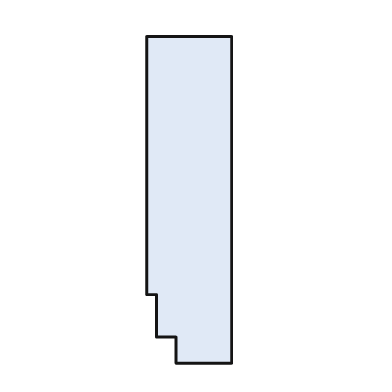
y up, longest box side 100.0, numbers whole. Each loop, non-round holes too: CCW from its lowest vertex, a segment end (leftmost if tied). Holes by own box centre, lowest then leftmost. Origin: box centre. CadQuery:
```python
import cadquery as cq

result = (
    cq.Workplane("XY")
    .moveTo(-4.0, -50.0)
    .lineTo(13.0, -50.0)
    .lineTo(13.0, 50.0)
    .lineTo(-13.0, 50.0)
    .lineTo(-13.0, -29.0)
    .lineTo(-10.0, -29.0)
    .lineTo(-10.0, -42.0)
    .lineTo(-4.0, -42.0)
    .close()
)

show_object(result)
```